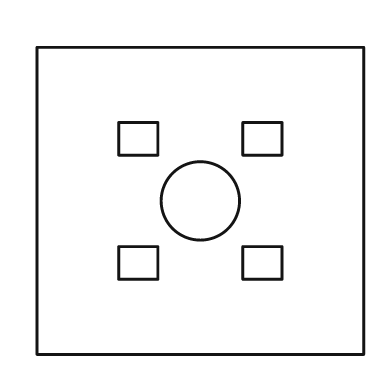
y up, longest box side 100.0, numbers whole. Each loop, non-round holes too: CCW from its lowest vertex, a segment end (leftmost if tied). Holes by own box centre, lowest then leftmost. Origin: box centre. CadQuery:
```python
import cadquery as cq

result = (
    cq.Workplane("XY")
    .moveTo(-50.0, -47.0)
    .lineTo(50.0, -47.0)
    .lineTo(50.0, 47.0)
    .lineTo(-50.0, 47.0)
    .close()
    .moveTo(-25.0, -24.0)
    .lineTo(-13.0, -24.0)
    .lineTo(-13.0, -14.0)
    .lineTo(-25.0, -14.0)
    .close()
    .moveTo(13.0, -24.0)
    .lineTo(25.0, -24.0)
    .lineTo(25.0, -14.0)
    .lineTo(13.0, -14.0)
    .close()
    .moveTo(0.0, 0.0)
    .circle(12.0)
    .moveTo(-25.0, 14.0)
    .lineTo(-13.0, 14.0)
    .lineTo(-13.0, 24.0)
    .lineTo(-25.0, 24.0)
    .close()
    .moveTo(13.0, 14.0)
    .lineTo(25.0, 14.0)
    .lineTo(25.0, 24.0)
    .lineTo(13.0, 24.0)
    .close()
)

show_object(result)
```